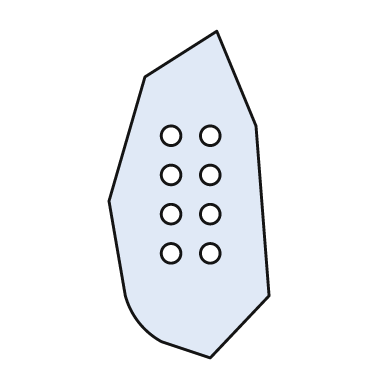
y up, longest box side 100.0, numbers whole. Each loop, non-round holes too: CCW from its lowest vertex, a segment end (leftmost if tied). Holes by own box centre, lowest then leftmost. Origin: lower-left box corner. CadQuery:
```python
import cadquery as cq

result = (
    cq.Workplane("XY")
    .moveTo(31.0, 0.0)
    .lineTo(49.0, 19.0)
    .lineTo(45.0, 71.0)
    .lineTo(33.0, 100.0)
    .lineTo(11.0, 86.0)
    .lineTo(0.0, 48.0)
    .lineTo(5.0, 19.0)
    .threePointArc((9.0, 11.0), (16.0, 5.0))
    .close()
    .moveTo(19.0, 32.0)
    .circle(3.0)
    .moveTo(31.0, 32.0)
    .circle(3.0)
    .moveTo(19.0, 44.0)
    .circle(3.0)
    .moveTo(31.0, 44.0)
    .circle(3.0)
    .moveTo(19.0, 56.0)
    .circle(3.0)
    .moveTo(31.0, 56.0)
    .circle(3.0)
    .moveTo(19.0, 68.0)
    .circle(3.0)
    .moveTo(31.0, 68.0)
    .circle(3.0)
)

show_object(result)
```